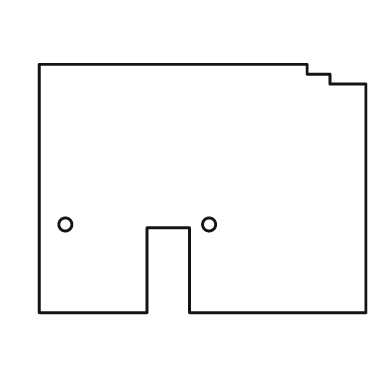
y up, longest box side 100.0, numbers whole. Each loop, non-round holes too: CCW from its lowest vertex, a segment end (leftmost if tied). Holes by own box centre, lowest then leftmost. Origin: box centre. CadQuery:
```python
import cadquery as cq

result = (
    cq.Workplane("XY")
    .moveTo(-50.0, -38.0)
    .lineTo(-17.0, -38.0)
    .lineTo(-17.0, -12.0)
    .lineTo(-4.0, -12.0)
    .lineTo(-4.0, -38.0)
    .lineTo(50.0, -38.0)
    .lineTo(50.0, 32.0)
    .lineTo(39.0, 32.0)
    .lineTo(39.0, 35.0)
    .lineTo(32.0, 35.0)
    .lineTo(32.0, 38.0)
    .lineTo(-50.0, 38.0)
    .close()
    .moveTo(-42.0, -11.0)
    .circle(2.0)
    .moveTo(2.0, -11.0)
    .circle(2.0)
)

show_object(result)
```